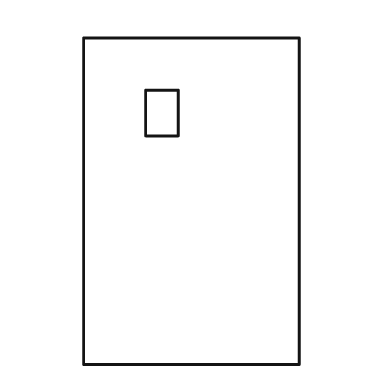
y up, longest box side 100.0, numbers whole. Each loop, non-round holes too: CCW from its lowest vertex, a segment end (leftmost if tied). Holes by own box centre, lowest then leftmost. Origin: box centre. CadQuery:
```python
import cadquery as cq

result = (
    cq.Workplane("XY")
    .moveTo(-33.0, -50.0)
    .lineTo(33.0, -50.0)
    .lineTo(33.0, 50.0)
    .lineTo(-33.0, 50.0)
    .close()
    .moveTo(-14.0, 20.0)
    .lineTo(-4.0, 20.0)
    .lineTo(-4.0, 34.0)
    .lineTo(-14.0, 34.0)
    .close()
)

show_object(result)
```